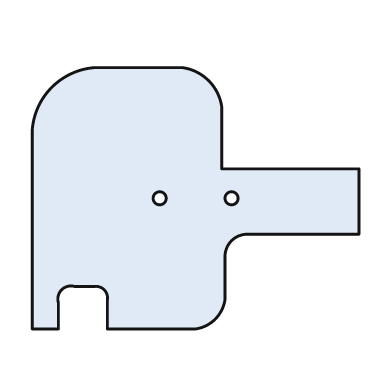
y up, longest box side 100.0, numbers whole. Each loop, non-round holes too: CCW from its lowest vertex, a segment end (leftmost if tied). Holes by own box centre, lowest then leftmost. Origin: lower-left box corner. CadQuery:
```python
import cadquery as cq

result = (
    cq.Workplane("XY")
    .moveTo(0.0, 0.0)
    .lineTo(8.0, 0.0)
    .lineTo(8.0, 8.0)
    .threePointArc((9.0, 12.0), (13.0, 13.0))
    .lineTo(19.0, 13.0)
    .threePointArc((22.0, 12.0), (23.0, 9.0))
    .lineTo(23.0, 0.0)
    .lineTo(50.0, 0.0)
    .threePointArc((56.0, 3.0), (59.0, 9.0))
    .lineTo(59.0, 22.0)
    .threePointArc((61.0, 27.0), (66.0, 29.0))
    .lineTo(100.0, 29.0)
    .lineTo(100.0, 49.0)
    .lineTo(58.0, 49.0)
    .lineTo(58.0, 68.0)
    .threePointArc((54.0, 76.0), (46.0, 80.0))
    .lineTo(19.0, 80.0)
    .threePointArc((6.0, 74.0), (0.0, 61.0))
    .close()
    .moveTo(39.0, 40.0)
    .circle(2.0)
    .moveTo(61.0, 40.0)
    .circle(2.0)
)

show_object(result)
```